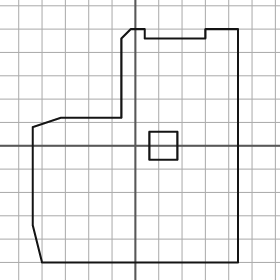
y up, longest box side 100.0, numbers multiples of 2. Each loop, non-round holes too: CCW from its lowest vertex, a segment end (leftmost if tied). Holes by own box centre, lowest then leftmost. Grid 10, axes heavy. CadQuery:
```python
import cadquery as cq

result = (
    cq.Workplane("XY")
    .moveTo(-40.0, -50.0)
    .lineTo(44.0, -50.0)
    .lineTo(44.0, 50.0)
    .lineTo(30.0, 50.0)
    .lineTo(30.0, 46.0)
    .lineTo(4.0, 46.0)
    .lineTo(4.0, 50.0)
    .lineTo(-2.0, 50.0)
    .lineTo(-6.0, 46.0)
    .lineTo(-6.0, 12.0)
    .lineTo(-32.0, 12.0)
    .lineTo(-44.0, 8.0)
    .lineTo(-44.0, -34.0)
    .close()
    .moveTo(6.0, -6.0)
    .lineTo(18.0, -6.0)
    .lineTo(18.0, 6.0)
    .lineTo(6.0, 6.0)
    .close()
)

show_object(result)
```